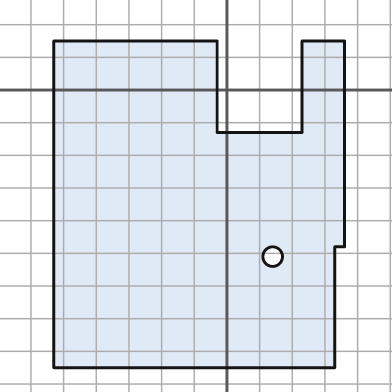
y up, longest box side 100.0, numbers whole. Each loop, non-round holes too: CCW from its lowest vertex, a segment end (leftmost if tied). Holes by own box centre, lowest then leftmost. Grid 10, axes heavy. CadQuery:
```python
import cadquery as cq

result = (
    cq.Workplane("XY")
    .moveTo(-53.0, -85.0)
    .lineTo(33.0, -85.0)
    .lineTo(33.0, -48.0)
    .lineTo(36.0, -48.0)
    .lineTo(36.0, 15.0)
    .lineTo(23.0, 15.0)
    .lineTo(23.0, -13.0)
    .lineTo(-3.0, -13.0)
    .lineTo(-3.0, 15.0)
    .lineTo(-53.0, 15.0)
    .close()
    .moveTo(14.0, -51.0)
    .circle(3.0)
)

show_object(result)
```